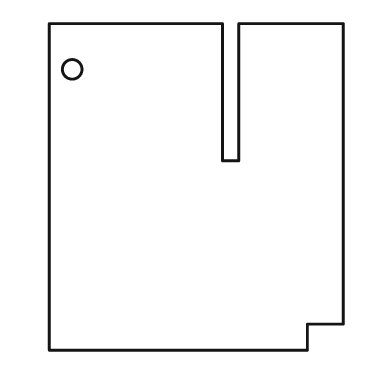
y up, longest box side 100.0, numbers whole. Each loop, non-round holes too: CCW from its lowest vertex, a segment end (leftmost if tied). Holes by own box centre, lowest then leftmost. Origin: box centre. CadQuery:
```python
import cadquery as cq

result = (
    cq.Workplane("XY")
    .moveTo(-45.0, -50.0)
    .lineTo(34.0, -50.0)
    .lineTo(34.0, -42.0)
    .lineTo(45.0, -42.0)
    .lineTo(45.0, 50.0)
    .lineTo(13.0, 50.0)
    .lineTo(13.0, 8.0)
    .lineTo(8.0, 8.0)
    .lineTo(8.0, 50.0)
    .lineTo(-45.0, 50.0)
    .close()
    .moveTo(-38.0, 36.0)
    .circle(3.0)
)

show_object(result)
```